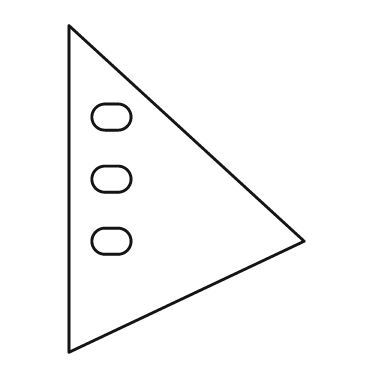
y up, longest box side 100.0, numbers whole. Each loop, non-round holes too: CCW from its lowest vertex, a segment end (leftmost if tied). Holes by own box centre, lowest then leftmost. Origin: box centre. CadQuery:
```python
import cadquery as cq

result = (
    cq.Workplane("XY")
    .moveTo(-36.0, -50.0)
    .lineTo(36.0, -16.0)
    .lineTo(-36.0, 50.0)
    .close()
    .moveTo(-25.0, -20.0)
    .lineTo(-21.0, -20.0)
    .threePointArc((-17.0, -16.0), (-21.0, -12.0))
    .lineTo(-25.0, -12.0)
    .threePointArc((-29.0, -16.0), (-25.0, -20.0))
    .close()
    .moveTo(-25.0, -1.0)
    .lineTo(-21.0, -1.0)
    .threePointArc((-17.0, 3.0), (-21.0, 7.0))
    .lineTo(-25.0, 7.0)
    .threePointArc((-29.0, 3.0), (-25.0, -1.0))
    .close()
    .moveTo(-25.0, 18.0)
    .lineTo(-21.0, 18.0)
    .threePointArc((-17.0, 22.0), (-21.0, 26.0))
    .lineTo(-25.0, 26.0)
    .threePointArc((-29.0, 22.0), (-25.0, 18.0))
    .close()
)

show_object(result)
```